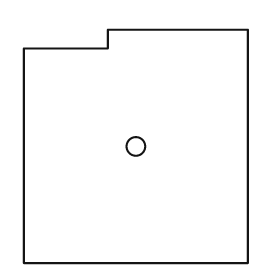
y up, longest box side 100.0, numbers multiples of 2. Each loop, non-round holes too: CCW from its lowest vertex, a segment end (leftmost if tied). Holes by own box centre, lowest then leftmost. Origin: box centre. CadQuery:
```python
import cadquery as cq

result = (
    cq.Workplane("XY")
    .moveTo(-48.0, -50.0)
    .lineTo(48.0, -50.0)
    .lineTo(48.0, 50.0)
    .lineTo(-12.0, 50.0)
    .lineTo(-12.0, 42.0)
    .lineTo(-48.0, 42.0)
    .close()
    .moveTo(0.0, 0.0)
    .circle(4.0)
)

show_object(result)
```